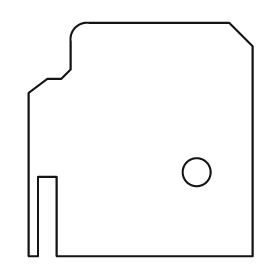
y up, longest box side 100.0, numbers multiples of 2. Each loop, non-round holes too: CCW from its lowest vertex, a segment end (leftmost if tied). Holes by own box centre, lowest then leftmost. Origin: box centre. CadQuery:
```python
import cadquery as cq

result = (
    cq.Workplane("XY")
    .moveTo(-48.0, -50.0)
    .lineTo(-44.0, -50.0)
    .lineTo(-44.0, -16.0)
    .lineTo(-36.0, -16.0)
    .lineTo(-36.0, -50.0)
    .lineTo(48.0, -50.0)
    .lineTo(48.0, 40.0)
    .lineTo(38.0, 50.0)
    .lineTo(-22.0, 50.0)
    .threePointArc((-28.0, 48.0), (-30.0, 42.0))
    .lineTo(-30.0, 30.0)
    .lineTo(-34.0, 26.0)
    .lineTo(-40.0, 26.0)
    .lineTo(-48.0, 20.0)
    .close()
    .moveTo(24.0, -14.0)
    .circle(6.0)
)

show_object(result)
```